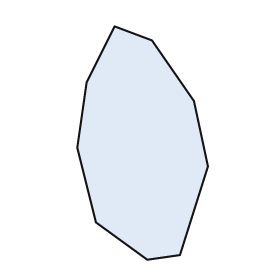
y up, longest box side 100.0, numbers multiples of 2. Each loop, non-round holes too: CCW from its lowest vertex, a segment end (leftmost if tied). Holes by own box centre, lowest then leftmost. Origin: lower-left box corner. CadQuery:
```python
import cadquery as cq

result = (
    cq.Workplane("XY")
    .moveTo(30.0, 0.0)
    .lineTo(44.0, 2.0)
    .lineTo(56.0, 40.0)
    .lineTo(50.0, 68.0)
    .lineTo(32.0, 94.0)
    .lineTo(16.0, 100.0)
    .lineTo(4.0, 76.0)
    .lineTo(0.0, 48.0)
    .lineTo(8.0, 16.0)
    .close()
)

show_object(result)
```